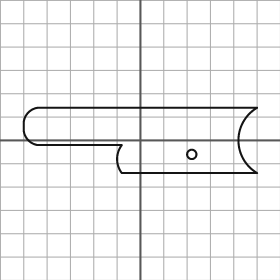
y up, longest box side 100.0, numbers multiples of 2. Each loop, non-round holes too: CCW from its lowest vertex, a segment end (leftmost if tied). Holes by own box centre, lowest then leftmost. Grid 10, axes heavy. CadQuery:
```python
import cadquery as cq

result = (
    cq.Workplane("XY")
    .moveTo(-8.0, -14.0)
    .lineTo(50.0, -14.0)
    .threePointArc((42.0, 0.0), (50.0, 14.0))
    .lineTo(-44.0, 14.0)
    .threePointArc((-48.0, 12.0), (-50.0, 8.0))
    .lineTo(-50.0, 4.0)
    .threePointArc((-48.0, 0.0), (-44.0, -2.0))
    .lineTo(-8.0, -2.0)
    .threePointArc((-10.0, -8.0), (-8.0, -14.0))
    .close()
    .moveTo(22.0, -6.0)
    .circle(2.0)
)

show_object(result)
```